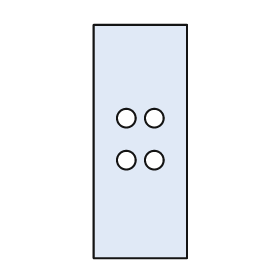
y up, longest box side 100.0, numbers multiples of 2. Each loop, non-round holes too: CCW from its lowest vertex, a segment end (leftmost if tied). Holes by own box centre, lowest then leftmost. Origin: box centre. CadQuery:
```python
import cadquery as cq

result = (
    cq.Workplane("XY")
    .moveTo(-20.0, -50.0)
    .lineTo(20.0, -50.0)
    .lineTo(20.0, 50.0)
    .lineTo(-20.0, 50.0)
    .close()
    .moveTo(-6.0, -8.0)
    .circle(4.0)
    .moveTo(6.0, -8.0)
    .circle(4.0)
    .moveTo(-6.0, 10.0)
    .circle(4.0)
    .moveTo(6.0, 10.0)
    .circle(4.0)
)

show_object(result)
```